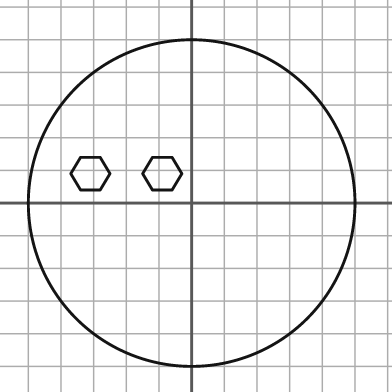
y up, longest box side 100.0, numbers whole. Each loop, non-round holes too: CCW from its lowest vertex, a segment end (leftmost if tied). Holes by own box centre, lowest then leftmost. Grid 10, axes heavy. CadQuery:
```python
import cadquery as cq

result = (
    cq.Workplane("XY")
    .moveTo(0.0, 0.0)
    .circle(50.0)
    .moveTo(-34.0, 4.0)
    .lineTo(-28.0, 4.0)
    .lineTo(-25.0, 9.0)
    .lineTo(-28.0, 14.0)
    .lineTo(-34.0, 14.0)
    .lineTo(-37.0, 9.0)
    .close()
    .moveTo(-12.0, 4.0)
    .lineTo(-6.0, 4.0)
    .lineTo(-3.0, 9.0)
    .lineTo(-6.0, 14.0)
    .lineTo(-12.0, 14.0)
    .lineTo(-15.0, 9.0)
    .close()
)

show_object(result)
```